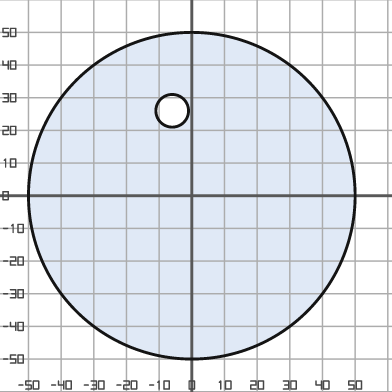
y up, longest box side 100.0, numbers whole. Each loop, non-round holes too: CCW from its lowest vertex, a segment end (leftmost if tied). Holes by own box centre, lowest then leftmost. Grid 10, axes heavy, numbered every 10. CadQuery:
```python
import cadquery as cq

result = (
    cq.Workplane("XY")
    .moveTo(0.0, 0.0)
    .circle(50.0)
    .moveTo(-6.0, 26.0)
    .circle(5.0)
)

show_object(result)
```